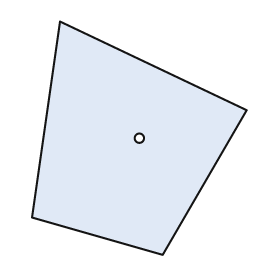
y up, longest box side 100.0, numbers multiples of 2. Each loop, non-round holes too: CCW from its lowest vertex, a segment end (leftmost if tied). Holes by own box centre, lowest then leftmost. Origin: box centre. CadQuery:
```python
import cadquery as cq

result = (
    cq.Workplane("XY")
    .moveTo(10.0, -50.0)
    .lineTo(46.0, 12.0)
    .lineTo(-34.0, 50.0)
    .lineTo(-46.0, -34.0)
    .close()
    .moveTo(0.0, 0.0)
    .circle(2.0)
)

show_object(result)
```